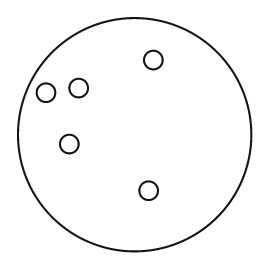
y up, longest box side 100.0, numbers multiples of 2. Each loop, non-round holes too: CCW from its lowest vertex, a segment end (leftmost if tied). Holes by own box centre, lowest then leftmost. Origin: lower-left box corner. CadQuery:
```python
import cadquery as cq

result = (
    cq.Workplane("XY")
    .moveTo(50.0, 50.0)
    .circle(50.0)
    .moveTo(56.0, 26.0)
    .circle(4.0)
    .moveTo(22.0, 46.0)
    .circle(4.0)
    .moveTo(12.0, 68.0)
    .circle(4.0)
    .moveTo(26.0, 70.0)
    .circle(4.0)
    .moveTo(58.0, 82.0)
    .circle(4.0)
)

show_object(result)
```